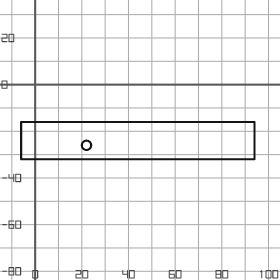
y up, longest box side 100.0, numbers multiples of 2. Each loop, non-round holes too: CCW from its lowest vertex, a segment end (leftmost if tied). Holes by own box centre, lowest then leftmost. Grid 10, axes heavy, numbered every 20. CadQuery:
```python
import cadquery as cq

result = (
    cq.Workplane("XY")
    .moveTo(-6.0, -32.0)
    .lineTo(94.0, -32.0)
    .lineTo(94.0, -16.0)
    .lineTo(-6.0, -16.0)
    .close()
    .moveTo(22.0, -26.0)
    .circle(2.0)
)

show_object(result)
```